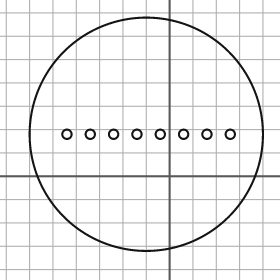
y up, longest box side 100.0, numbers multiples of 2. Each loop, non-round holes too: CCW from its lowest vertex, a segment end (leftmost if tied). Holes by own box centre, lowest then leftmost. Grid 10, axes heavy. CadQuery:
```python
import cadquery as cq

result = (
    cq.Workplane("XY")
    .moveTo(-10.0, 18.0)
    .circle(50.0)
    .moveTo(-44.0, 18.0)
    .circle(2.0)
    .moveTo(-34.0, 18.0)
    .circle(2.0)
    .moveTo(-24.0, 18.0)
    .circle(2.0)
    .moveTo(-14.0, 18.0)
    .circle(2.0)
    .moveTo(-4.0, 18.0)
    .circle(2.0)
    .moveTo(6.0, 18.0)
    .circle(2.0)
    .moveTo(16.0, 18.0)
    .circle(2.0)
    .moveTo(26.0, 18.0)
    .circle(2.0)
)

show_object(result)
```